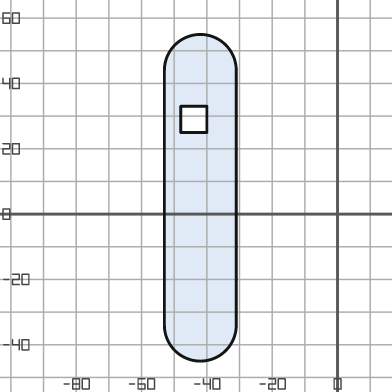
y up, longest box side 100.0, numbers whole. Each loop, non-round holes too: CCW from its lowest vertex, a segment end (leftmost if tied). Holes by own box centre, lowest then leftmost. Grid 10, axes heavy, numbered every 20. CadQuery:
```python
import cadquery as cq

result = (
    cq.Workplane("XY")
    .moveTo(-53.0, -34.0)
    .threePointArc((-42.0, -45.0), (-31.0, -34.0))
    .lineTo(-31.0, 44.0)
    .threePointArc((-42.0, 55.0), (-53.0, 44.0))
    .close()
    .moveTo(-48.0, 25.0)
    .lineTo(-40.0, 25.0)
    .lineTo(-40.0, 33.0)
    .lineTo(-48.0, 33.0)
    .close()
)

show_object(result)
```